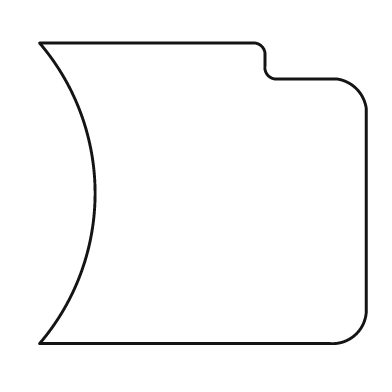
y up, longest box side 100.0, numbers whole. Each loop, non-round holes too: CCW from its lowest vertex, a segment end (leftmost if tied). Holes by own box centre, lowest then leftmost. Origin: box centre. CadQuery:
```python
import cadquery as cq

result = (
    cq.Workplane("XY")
    .moveTo(-50.0, -46.0)
    .lineTo(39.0, -46.0)
    .threePointArc((47.0, -43.0), (50.0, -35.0))
    .lineTo(50.0, 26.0)
    .threePointArc((47.0, 32.0), (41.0, 35.0))
    .lineTo(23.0, 35.0)
    .threePointArc((20.0, 36.0), (19.0, 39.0))
    .lineTo(19.0, 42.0)
    .threePointArc((18.0, 45.0), (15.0, 46.0))
    .lineTo(-50.0, 46.0)
    .threePointArc((-33.0, 0.0), (-50.0, -46.0))
    .close()
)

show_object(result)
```